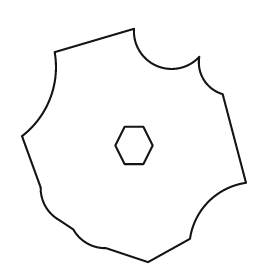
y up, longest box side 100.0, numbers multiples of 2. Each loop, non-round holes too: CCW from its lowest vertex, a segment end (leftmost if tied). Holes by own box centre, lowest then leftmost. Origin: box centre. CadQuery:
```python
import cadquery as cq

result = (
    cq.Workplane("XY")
    .moveTo(6.0, -50.0)
    .lineTo(24.0, -40.0)
    .threePointArc((32.0, -24.0), (48.0, -16.0))
    .lineTo(38.0, 22.0)
    .threePointArc((30.0, 28.0), (28.0, 38.0))
    .threePointArc((10.0, 34.0), (0.0, 50.0))
    .lineTo(-34.0, 40.0)
    .threePointArc((-36.0, 20.0), (-48.0, 4.0))
    .lineTo(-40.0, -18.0)
    .threePointArc((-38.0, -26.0), (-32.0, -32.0))
    .lineTo(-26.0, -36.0)
    .threePointArc((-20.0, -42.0), (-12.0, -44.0))
    .close()
    .moveTo(-4.0, -8.0)
    .lineTo(4.0, -8.0)
    .lineTo(8.0, 0.0)
    .lineTo(4.0, 8.0)
    .lineTo(-4.0, 8.0)
    .lineTo(-8.0, 0.0)
    .close()
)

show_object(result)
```